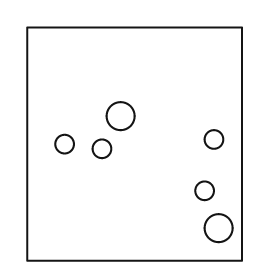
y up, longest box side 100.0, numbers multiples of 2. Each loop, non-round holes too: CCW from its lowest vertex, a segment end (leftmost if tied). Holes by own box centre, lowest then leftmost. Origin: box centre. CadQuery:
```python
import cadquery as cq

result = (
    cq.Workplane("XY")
    .moveTo(-46.0, -50.0)
    .lineTo(46.0, -50.0)
    .lineTo(46.0, 50.0)
    .lineTo(-46.0, 50.0)
    .close()
    .moveTo(36.0, -36.0)
    .circle(6.0)
    .moveTo(30.0, -20.0)
    .circle(4.0)
    .moveTo(-14.0, -2.0)
    .circle(4.0)
    .moveTo(-30.0, 0.0)
    .circle(4.0)
    .moveTo(34.0, 2.0)
    .circle(4.0)
    .moveTo(-6.0, 12.0)
    .circle(6.0)
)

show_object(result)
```